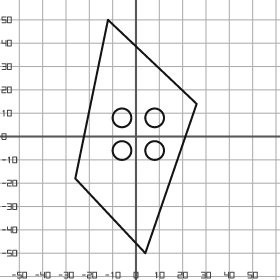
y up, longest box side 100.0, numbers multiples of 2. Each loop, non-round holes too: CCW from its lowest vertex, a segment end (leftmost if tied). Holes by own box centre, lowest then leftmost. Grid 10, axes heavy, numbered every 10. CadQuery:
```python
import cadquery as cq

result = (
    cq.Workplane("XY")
    .moveTo(4.0, -50.0)
    .lineTo(26.0, 14.0)
    .lineTo(-12.0, 50.0)
    .lineTo(-26.0, -18.0)
    .close()
    .moveTo(-6.0, -6.0)
    .circle(4.0)
    .moveTo(8.0, -6.0)
    .circle(4.0)
    .moveTo(-6.0, 8.0)
    .circle(4.0)
    .moveTo(8.0, 8.0)
    .circle(4.0)
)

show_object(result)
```